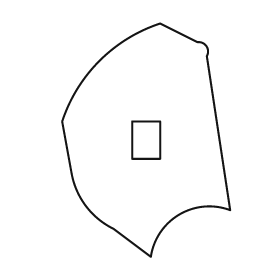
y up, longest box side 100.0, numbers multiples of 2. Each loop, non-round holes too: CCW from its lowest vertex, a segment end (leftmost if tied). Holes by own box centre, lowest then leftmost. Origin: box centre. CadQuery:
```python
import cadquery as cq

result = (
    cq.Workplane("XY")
    .moveTo(2.0, -50.0)
    .threePointArc((14.0, -32.0), (36.0, -30.0))
    .lineTo(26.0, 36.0)
    .threePointArc((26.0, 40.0), (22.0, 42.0))
    .lineTo(6.0, 50.0)
    .threePointArc((-20.0, 34.0), (-36.0, 8.0))
    .lineTo(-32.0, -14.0)
    .threePointArc((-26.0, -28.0), (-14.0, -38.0))
    .close()
    .moveTo(-6.0, -8.0)
    .lineTo(6.0, -8.0)
    .lineTo(6.0, 8.0)
    .lineTo(-6.0, 8.0)
    .close()
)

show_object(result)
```